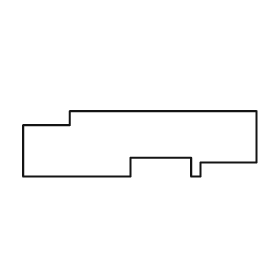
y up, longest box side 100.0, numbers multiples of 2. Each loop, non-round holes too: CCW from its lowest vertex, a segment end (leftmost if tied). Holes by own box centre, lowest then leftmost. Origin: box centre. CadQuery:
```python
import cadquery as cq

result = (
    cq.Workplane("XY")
    .moveTo(-50.0, -14.0)
    .lineTo(-4.0, -14.0)
    .lineTo(-4.0, -6.0)
    .lineTo(22.0, -6.0)
    .lineTo(22.0, -14.0)
    .lineTo(26.0, -14.0)
    .lineTo(26.0, -8.0)
    .lineTo(50.0, -8.0)
    .lineTo(50.0, 14.0)
    .lineTo(-30.0, 14.0)
    .lineTo(-30.0, 8.0)
    .lineTo(-50.0, 8.0)
    .close()
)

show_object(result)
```